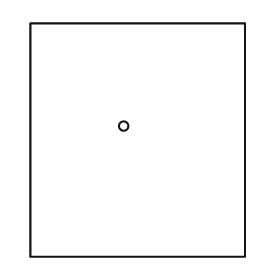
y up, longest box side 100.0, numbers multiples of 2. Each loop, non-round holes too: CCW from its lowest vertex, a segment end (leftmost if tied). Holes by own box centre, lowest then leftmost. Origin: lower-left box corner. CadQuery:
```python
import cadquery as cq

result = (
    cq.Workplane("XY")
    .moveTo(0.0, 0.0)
    .lineTo(92.0, 0.0)
    .lineTo(92.0, 100.0)
    .lineTo(0.0, 100.0)
    .close()
    .moveTo(40.0, 56.0)
    .circle(2.0)
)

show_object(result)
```